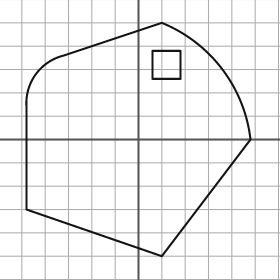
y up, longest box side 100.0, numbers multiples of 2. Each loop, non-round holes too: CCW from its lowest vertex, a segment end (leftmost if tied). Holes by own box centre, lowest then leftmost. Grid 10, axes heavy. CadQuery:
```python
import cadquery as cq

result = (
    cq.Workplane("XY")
    .moveTo(10.0, -50.0)
    .lineTo(48.0, 0.0)
    .threePointArc((36.0, 30.0), (10.0, 50.0))
    .lineTo(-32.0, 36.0)
    .threePointArc((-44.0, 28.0), (-48.0, 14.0))
    .lineTo(-48.0, -30.0)
    .close()
    .moveTo(6.0, 26.0)
    .lineTo(18.0, 26.0)
    .lineTo(18.0, 38.0)
    .lineTo(6.0, 38.0)
    .close()
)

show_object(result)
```